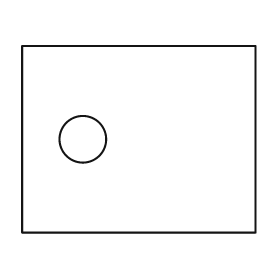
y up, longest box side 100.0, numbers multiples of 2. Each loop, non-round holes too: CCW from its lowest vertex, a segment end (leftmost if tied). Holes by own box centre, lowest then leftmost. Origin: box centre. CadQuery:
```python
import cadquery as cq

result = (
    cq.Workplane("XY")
    .moveTo(-50.0, -40.0)
    .lineTo(50.0, -40.0)
    .lineTo(50.0, 40.0)
    .lineTo(-50.0, 40.0)
    .close()
    .moveTo(-24.0, 0.0)
    .circle(10.0)
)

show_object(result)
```